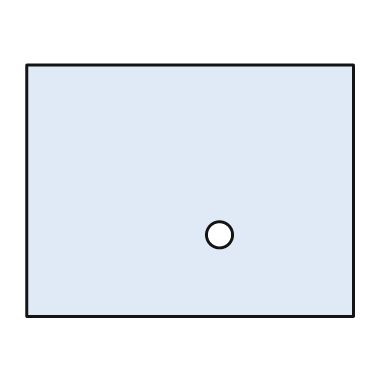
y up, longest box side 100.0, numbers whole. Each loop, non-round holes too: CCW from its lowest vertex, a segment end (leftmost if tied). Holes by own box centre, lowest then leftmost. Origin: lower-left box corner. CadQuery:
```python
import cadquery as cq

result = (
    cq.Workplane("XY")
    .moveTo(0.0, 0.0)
    .lineTo(100.0, 0.0)
    .lineTo(100.0, 77.0)
    .lineTo(0.0, 77.0)
    .close()
    .moveTo(59.0, 25.0)
    .circle(4.0)
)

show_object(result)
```